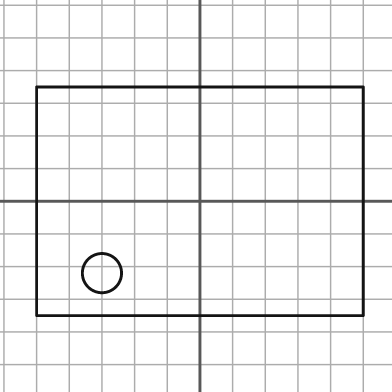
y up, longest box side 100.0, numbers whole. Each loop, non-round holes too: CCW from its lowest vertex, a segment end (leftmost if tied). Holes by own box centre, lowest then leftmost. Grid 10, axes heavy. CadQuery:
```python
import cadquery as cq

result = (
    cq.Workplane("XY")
    .moveTo(-50.0, -35.0)
    .lineTo(50.0, -35.0)
    .lineTo(50.0, 35.0)
    .lineTo(-50.0, 35.0)
    .close()
    .moveTo(-30.0, -22.0)
    .circle(6.0)
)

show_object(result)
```